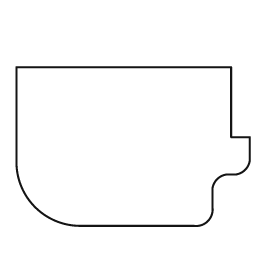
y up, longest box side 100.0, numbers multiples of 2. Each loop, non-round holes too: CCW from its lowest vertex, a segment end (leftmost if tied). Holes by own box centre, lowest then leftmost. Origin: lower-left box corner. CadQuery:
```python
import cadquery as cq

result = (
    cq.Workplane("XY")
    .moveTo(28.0, 0.0)
    .lineTo(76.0, 0.0)
    .threePointArc((82.0, 2.0), (84.0, 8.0))
    .lineTo(84.0, 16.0)
    .threePointArc((86.0, 20.0), (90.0, 22.0))
    .lineTo(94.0, 22.0)
    .threePointArc((98.0, 24.0), (100.0, 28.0))
    .lineTo(100.0, 38.0)
    .lineTo(92.0, 38.0)
    .lineTo(92.0, 68.0)
    .lineTo(0.0, 68.0)
    .lineTo(0.0, 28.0)
    .threePointArc((8.0, 8.0), (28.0, 0.0))
    .close()
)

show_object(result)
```